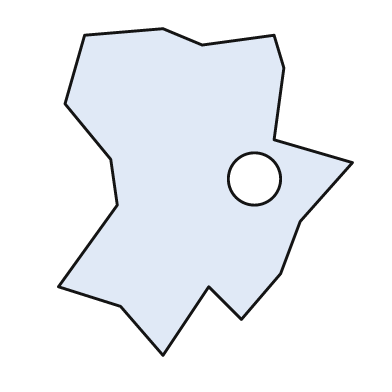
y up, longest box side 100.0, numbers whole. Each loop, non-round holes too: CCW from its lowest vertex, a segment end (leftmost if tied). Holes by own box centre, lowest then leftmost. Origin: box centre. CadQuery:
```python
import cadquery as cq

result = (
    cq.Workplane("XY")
    .moveTo(-13.0, -50.0)
    .lineTo(1.0, -29.0)
    .lineTo(11.0, -39.0)
    .lineTo(23.0, -25.0)
    .lineTo(29.0, -9.0)
    .lineTo(45.0, 9.0)
    .lineTo(21.0, 16.0)
    .lineTo(24.0, 38.0)
    .lineTo(21.0, 48.0)
    .lineTo(-1.0, 45.0)
    .lineTo(-13.0, 50.0)
    .lineTo(-37.0, 48.0)
    .lineTo(-43.0, 27.0)
    .lineTo(-29.0, 10.0)
    .lineTo(-27.0, -4.0)
    .lineTo(-45.0, -29.0)
    .lineTo(-26.0, -35.0)
    .close()
    .moveTo(15.0, 4.0)
    .circle(8.0)
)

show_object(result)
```